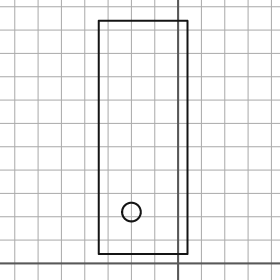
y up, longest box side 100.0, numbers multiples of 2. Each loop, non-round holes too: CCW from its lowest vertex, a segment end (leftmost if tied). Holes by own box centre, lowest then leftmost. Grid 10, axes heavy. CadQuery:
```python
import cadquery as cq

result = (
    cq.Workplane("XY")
    .moveTo(-34.0, 4.0)
    .lineTo(4.0, 4.0)
    .lineTo(4.0, 104.0)
    .lineTo(-34.0, 104.0)
    .close()
    .moveTo(-20.0, 22.0)
    .circle(4.0)
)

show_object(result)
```